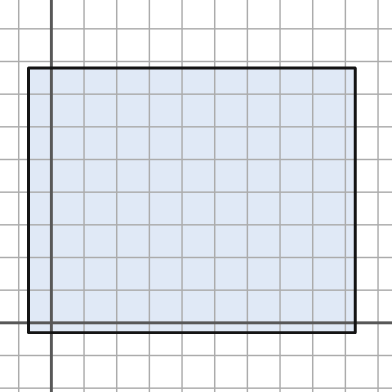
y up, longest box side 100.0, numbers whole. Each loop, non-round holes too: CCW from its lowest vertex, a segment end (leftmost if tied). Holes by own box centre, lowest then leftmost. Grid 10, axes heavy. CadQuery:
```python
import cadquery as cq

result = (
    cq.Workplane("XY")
    .moveTo(-7.0, -3.0)
    .lineTo(93.0, -3.0)
    .lineTo(93.0, 78.0)
    .lineTo(-7.0, 78.0)
    .close()
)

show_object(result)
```